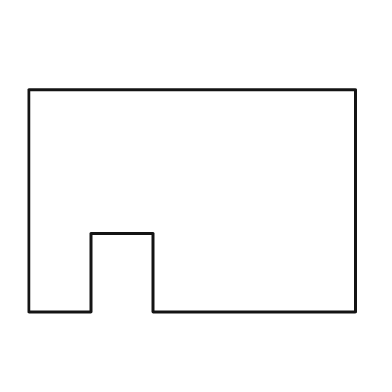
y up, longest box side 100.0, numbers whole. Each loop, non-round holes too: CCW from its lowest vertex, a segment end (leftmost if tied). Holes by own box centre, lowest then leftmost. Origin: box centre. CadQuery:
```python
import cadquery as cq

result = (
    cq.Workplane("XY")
    .moveTo(-50.0, -34.0)
    .lineTo(-31.0, -34.0)
    .lineTo(-31.0, -10.0)
    .lineTo(-12.0, -10.0)
    .lineTo(-12.0, -34.0)
    .lineTo(50.0, -34.0)
    .lineTo(50.0, 34.0)
    .lineTo(-50.0, 34.0)
    .close()
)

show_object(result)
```